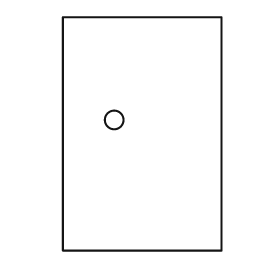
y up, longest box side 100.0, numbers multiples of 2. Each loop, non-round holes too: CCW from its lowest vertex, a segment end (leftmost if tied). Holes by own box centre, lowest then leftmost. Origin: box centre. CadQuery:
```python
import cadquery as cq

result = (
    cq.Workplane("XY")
    .moveTo(-34.0, -50.0)
    .lineTo(34.0, -50.0)
    .lineTo(34.0, 50.0)
    .lineTo(-34.0, 50.0)
    .close()
    .moveTo(-12.0, 6.0)
    .circle(4.0)
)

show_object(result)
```